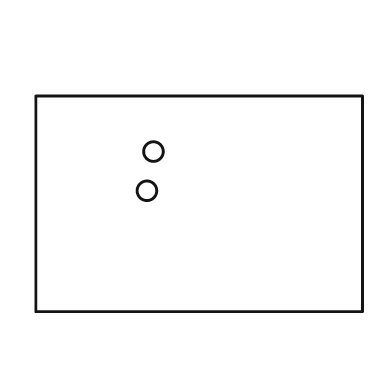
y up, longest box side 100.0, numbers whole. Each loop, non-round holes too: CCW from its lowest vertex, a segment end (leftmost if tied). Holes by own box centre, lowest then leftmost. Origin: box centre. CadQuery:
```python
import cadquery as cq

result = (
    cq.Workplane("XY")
    .moveTo(-50.0, -33.0)
    .lineTo(50.0, -33.0)
    .lineTo(50.0, 33.0)
    .lineTo(-50.0, 33.0)
    .close()
    .moveTo(-16.0, 4.0)
    .circle(3.0)
    .moveTo(-14.0, 16.0)
    .circle(3.0)
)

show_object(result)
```